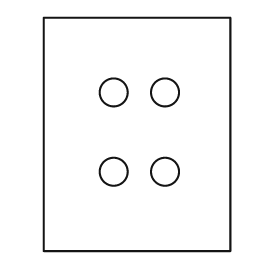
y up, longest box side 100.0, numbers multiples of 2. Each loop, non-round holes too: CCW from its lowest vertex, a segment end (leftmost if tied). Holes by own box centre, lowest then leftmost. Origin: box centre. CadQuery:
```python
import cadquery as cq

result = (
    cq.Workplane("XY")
    .moveTo(-40.0, -50.0)
    .lineTo(40.0, -50.0)
    .lineTo(40.0, 50.0)
    .lineTo(-40.0, 50.0)
    .close()
    .moveTo(-10.0, -16.0)
    .circle(6.0)
    .moveTo(12.0, -16.0)
    .circle(6.0)
    .moveTo(-10.0, 18.0)
    .circle(6.0)
    .moveTo(12.0, 18.0)
    .circle(6.0)
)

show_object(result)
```